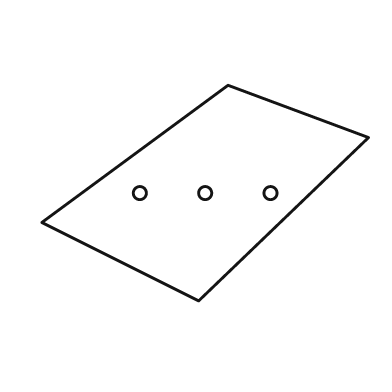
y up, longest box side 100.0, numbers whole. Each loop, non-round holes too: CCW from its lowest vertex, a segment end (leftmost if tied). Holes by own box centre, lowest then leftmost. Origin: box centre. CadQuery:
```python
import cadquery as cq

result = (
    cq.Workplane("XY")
    .moveTo(-2.0, -33.0)
    .lineTo(50.0, 17.0)
    .lineTo(7.0, 33.0)
    .lineTo(-50.0, -9.0)
    .close()
    .moveTo(-20.0, 0.0)
    .circle(2.0)
    .moveTo(0.0, 0.0)
    .circle(2.0)
    .moveTo(20.0, 0.0)
    .circle(2.0)
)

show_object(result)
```